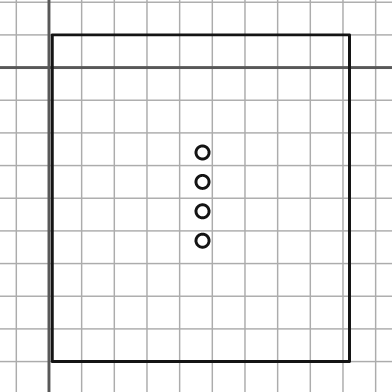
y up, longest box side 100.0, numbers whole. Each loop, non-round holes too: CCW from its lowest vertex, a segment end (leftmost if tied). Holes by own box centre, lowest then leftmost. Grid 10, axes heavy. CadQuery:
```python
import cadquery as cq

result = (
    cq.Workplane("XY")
    .moveTo(1.0, -90.0)
    .lineTo(92.0, -90.0)
    .lineTo(92.0, 10.0)
    .lineTo(1.0, 10.0)
    .close()
    .moveTo(47.0, -53.0)
    .circle(2.0)
    .moveTo(47.0, -44.0)
    .circle(2.0)
    .moveTo(47.0, -35.0)
    .circle(2.0)
    .moveTo(47.0, -26.0)
    .circle(2.0)
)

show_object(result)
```